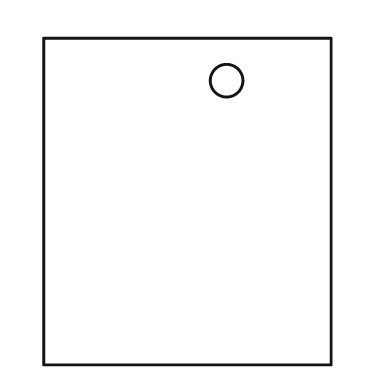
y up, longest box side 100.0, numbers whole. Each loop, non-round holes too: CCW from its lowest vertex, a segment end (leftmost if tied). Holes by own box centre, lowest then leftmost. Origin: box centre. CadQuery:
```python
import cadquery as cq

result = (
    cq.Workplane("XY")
    .moveTo(-44.0, -50.0)
    .lineTo(44.0, -50.0)
    .lineTo(44.0, 50.0)
    .lineTo(-44.0, 50.0)
    .close()
    .moveTo(12.0, 37.0)
    .circle(5.0)
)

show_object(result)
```